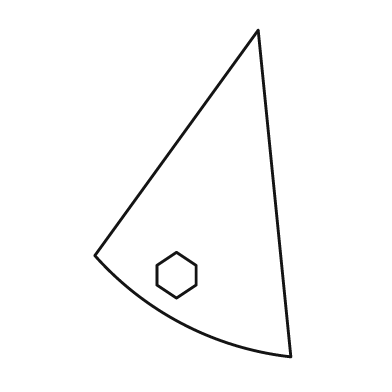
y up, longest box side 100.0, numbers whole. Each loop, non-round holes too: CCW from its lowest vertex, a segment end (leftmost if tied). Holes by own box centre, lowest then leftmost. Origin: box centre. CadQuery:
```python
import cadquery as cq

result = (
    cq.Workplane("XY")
    .moveTo(30.0, -50.0)
    .lineTo(20.0, 50.0)
    .lineTo(-30.0, -19.0)
    .threePointArc((-3.0, -40.0), (30.0, -50.0))
    .close()
    .moveTo(-5.0, -32.0)
    .lineTo(1.0, -28.0)
    .lineTo(1.0, -22.0)
    .lineTo(-5.0, -18.0)
    .lineTo(-11.0, -22.0)
    .lineTo(-11.0, -28.0)
    .close()
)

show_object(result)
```